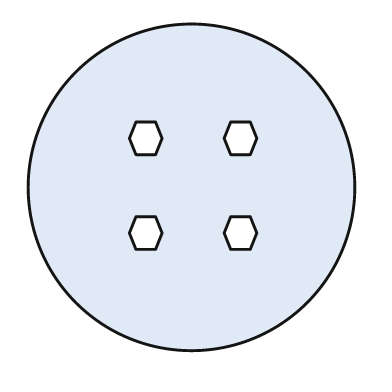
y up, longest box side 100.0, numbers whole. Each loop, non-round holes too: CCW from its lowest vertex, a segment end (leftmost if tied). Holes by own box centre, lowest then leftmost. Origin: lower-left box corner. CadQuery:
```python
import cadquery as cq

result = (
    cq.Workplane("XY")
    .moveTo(50.0, 50.0)
    .circle(50.0)
    .moveTo(33.0, 31.0)
    .lineTo(39.0, 31.0)
    .lineTo(41.0, 36.0)
    .lineTo(39.0, 41.0)
    .lineTo(33.0, 41.0)
    .lineTo(31.0, 36.0)
    .close()
    .moveTo(62.0, 31.0)
    .lineTo(68.0, 31.0)
    .lineTo(70.0, 36.0)
    .lineTo(68.0, 41.0)
    .lineTo(62.0, 41.0)
    .lineTo(60.0, 36.0)
    .close()
    .moveTo(33.0, 60.0)
    .lineTo(39.0, 60.0)
    .lineTo(41.0, 65.0)
    .lineTo(39.0, 70.0)
    .lineTo(33.0, 70.0)
    .lineTo(31.0, 65.0)
    .close()
    .moveTo(62.0, 60.0)
    .lineTo(68.0, 60.0)
    .lineTo(70.0, 65.0)
    .lineTo(68.0, 70.0)
    .lineTo(62.0, 70.0)
    .lineTo(60.0, 65.0)
    .close()
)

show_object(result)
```